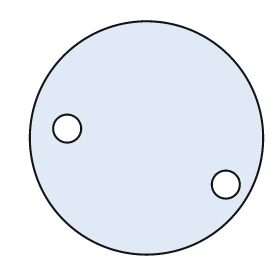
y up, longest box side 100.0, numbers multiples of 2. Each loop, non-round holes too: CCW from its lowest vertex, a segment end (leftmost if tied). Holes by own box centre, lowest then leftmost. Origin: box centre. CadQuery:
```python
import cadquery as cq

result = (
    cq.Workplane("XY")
    .moveTo(0.0, 0.0)
    .circle(50.0)
    .moveTo(34.0, -20.0)
    .circle(6.0)
    .moveTo(-34.0, 4.0)
    .circle(6.0)
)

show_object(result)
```